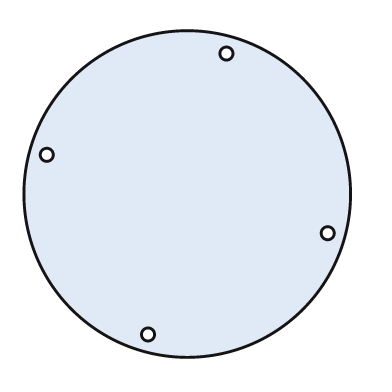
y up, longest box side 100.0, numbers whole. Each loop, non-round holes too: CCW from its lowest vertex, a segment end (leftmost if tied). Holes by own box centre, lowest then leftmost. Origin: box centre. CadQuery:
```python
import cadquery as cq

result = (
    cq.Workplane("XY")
    .moveTo(0.0, 0.0)
    .circle(50.0)
    .moveTo(-12.0, -43.0)
    .circle(2.0)
    .moveTo(43.0, -12.0)
    .circle(2.0)
    .moveTo(-43.0, 12.0)
    .circle(2.0)
    .moveTo(12.0, 43.0)
    .circle(2.0)
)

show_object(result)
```